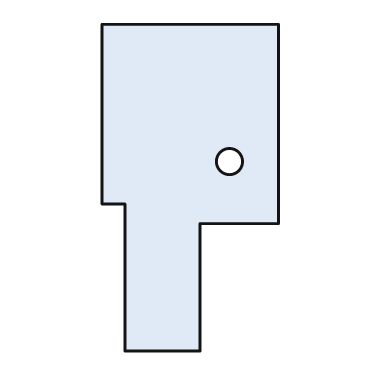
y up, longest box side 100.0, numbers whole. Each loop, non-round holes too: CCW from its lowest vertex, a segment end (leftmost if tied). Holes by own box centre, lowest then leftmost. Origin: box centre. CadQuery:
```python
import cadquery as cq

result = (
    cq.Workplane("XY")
    .moveTo(-20.0, -50.0)
    .lineTo(3.0, -50.0)
    .lineTo(3.0, -11.0)
    .lineTo(27.0, -11.0)
    .lineTo(27.0, 50.0)
    .lineTo(-27.0, 50.0)
    .lineTo(-27.0, -5.0)
    .lineTo(-20.0, -5.0)
    .close()
    .moveTo(12.0, 8.0)
    .circle(4.0)
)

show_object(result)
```